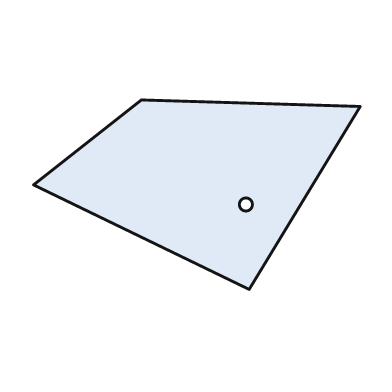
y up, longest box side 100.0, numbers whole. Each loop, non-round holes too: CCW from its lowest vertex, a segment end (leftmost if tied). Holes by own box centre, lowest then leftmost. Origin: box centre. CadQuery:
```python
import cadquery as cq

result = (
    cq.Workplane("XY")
    .moveTo(16.0, -29.0)
    .lineTo(50.0, 27.0)
    .lineTo(-17.0, 29.0)
    .lineTo(-50.0, 3.0)
    .close()
    .moveTo(15.0, -3.0)
    .circle(2.0)
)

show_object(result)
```